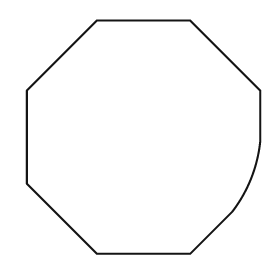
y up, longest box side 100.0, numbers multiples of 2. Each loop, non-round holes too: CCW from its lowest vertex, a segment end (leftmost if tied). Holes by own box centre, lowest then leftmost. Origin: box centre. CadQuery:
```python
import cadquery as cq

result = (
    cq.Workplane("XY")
    .moveTo(-20.0, -50.0)
    .lineTo(20.0, -50.0)
    .lineTo(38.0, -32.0)
    .threePointArc((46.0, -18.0), (50.0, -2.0))
    .lineTo(50.0, 20.0)
    .lineTo(20.0, 50.0)
    .lineTo(-20.0, 50.0)
    .lineTo(-50.0, 20.0)
    .lineTo(-50.0, -20.0)
    .close()
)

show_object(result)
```